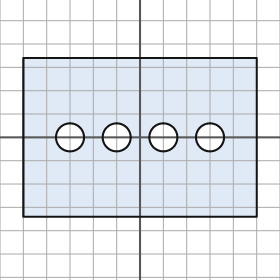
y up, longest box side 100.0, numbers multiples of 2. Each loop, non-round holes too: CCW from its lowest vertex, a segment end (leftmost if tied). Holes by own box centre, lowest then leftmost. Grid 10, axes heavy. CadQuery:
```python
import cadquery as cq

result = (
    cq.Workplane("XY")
    .moveTo(-50.0, -34.0)
    .lineTo(50.0, -34.0)
    .lineTo(50.0, 34.0)
    .lineTo(-50.0, 34.0)
    .close()
    .moveTo(-30.0, 0.0)
    .circle(6.0)
    .moveTo(-10.0, 0.0)
    .circle(6.0)
    .moveTo(10.0, 0.0)
    .circle(6.0)
    .moveTo(30.0, 0.0)
    .circle(6.0)
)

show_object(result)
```